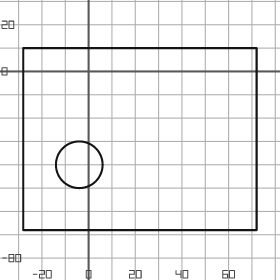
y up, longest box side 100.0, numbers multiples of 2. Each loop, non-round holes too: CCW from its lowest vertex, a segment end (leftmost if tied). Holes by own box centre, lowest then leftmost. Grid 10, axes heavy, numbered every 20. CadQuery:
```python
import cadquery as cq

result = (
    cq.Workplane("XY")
    .moveTo(-28.0, -68.0)
    .lineTo(72.0, -68.0)
    .lineTo(72.0, 10.0)
    .lineTo(-28.0, 10.0)
    .close()
    .moveTo(-4.0, -40.0)
    .circle(10.0)
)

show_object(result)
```